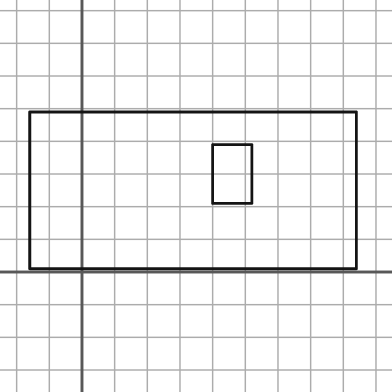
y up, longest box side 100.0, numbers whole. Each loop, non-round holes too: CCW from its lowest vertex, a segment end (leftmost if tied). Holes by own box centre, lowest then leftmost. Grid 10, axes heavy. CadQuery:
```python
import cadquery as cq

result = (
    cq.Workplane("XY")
    .moveTo(-16.0, 1.0)
    .lineTo(84.0, 1.0)
    .lineTo(84.0, 49.0)
    .lineTo(-16.0, 49.0)
    .close()
    .moveTo(40.0, 21.0)
    .lineTo(52.0, 21.0)
    .lineTo(52.0, 39.0)
    .lineTo(40.0, 39.0)
    .close()
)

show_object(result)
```